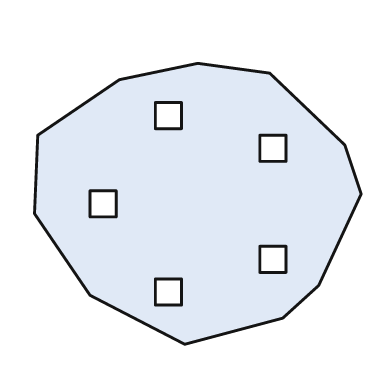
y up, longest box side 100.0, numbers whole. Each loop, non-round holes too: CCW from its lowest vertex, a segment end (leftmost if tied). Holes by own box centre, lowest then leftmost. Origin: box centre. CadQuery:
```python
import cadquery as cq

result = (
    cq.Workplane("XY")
    .moveTo(-4.0, -43.0)
    .lineTo(26.0, -35.0)
    .lineTo(37.0, -25.0)
    .lineTo(50.0, 3.0)
    .lineTo(45.0, 18.0)
    .lineTo(22.0, 40.0)
    .lineTo(0.0, 43.0)
    .lineTo(-24.0, 38.0)
    .lineTo(-49.0, 21.0)
    .lineTo(-50.0, -3.0)
    .lineTo(-33.0, -28.0)
    .close()
    .moveTo(-13.0, -31.0)
    .lineTo(-5.0, -31.0)
    .lineTo(-5.0, -23.0)
    .lineTo(-13.0, -23.0)
    .close()
    .moveTo(19.0, -21.0)
    .lineTo(27.0, -21.0)
    .lineTo(27.0, -13.0)
    .lineTo(19.0, -13.0)
    .close()
    .moveTo(-33.0, -4.0)
    .lineTo(-25.0, -4.0)
    .lineTo(-25.0, 4.0)
    .lineTo(-33.0, 4.0)
    .close()
    .moveTo(19.0, 13.0)
    .lineTo(27.0, 13.0)
    .lineTo(27.0, 21.0)
    .lineTo(19.0, 21.0)
    .close()
    .moveTo(-13.0, 23.0)
    .lineTo(-5.0, 23.0)
    .lineTo(-5.0, 31.0)
    .lineTo(-13.0, 31.0)
    .close()
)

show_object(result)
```